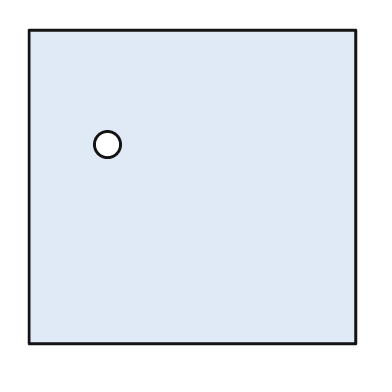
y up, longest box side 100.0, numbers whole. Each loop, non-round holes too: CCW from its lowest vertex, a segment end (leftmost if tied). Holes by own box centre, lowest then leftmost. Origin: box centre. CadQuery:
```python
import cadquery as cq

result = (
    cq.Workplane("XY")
    .moveTo(-50.0, -48.0)
    .lineTo(50.0, -48.0)
    .lineTo(50.0, 48.0)
    .lineTo(-50.0, 48.0)
    .close()
    .moveTo(-26.0, 13.0)
    .circle(4.0)
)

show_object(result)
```